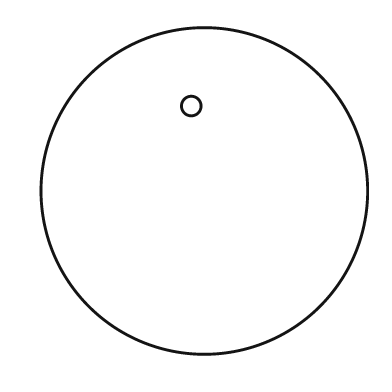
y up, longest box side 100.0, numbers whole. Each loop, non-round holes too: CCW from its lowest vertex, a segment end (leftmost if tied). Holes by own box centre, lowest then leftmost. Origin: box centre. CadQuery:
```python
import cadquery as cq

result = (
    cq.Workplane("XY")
    .moveTo(0.0, 0.0)
    .circle(50.0)
    .moveTo(-4.0, 26.0)
    .circle(3.0)
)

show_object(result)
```